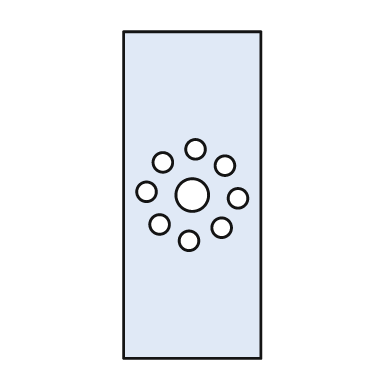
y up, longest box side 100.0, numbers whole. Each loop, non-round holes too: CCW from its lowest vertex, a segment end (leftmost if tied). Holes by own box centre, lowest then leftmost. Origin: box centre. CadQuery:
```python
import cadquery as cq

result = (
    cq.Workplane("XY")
    .moveTo(-21.0, -50.0)
    .lineTo(21.0, -50.0)
    .lineTo(21.0, 50.0)
    .lineTo(-21.0, 50.0)
    .close()
    .moveTo(-1.0, -14.0)
    .circle(3.0)
    .moveTo(9.0, -10.0)
    .circle(3.0)
    .moveTo(-10.0, -9.0)
    .circle(3.0)
    .moveTo(14.0, -1.0)
    .circle(3.0)
    .moveTo(0.0, 0.0)
    .circle(5.0)
    .moveTo(-14.0, 1.0)
    .circle(3.0)
    .moveTo(10.0, 9.0)
    .circle(3.0)
    .moveTo(-9.0, 10.0)
    .circle(3.0)
    .moveTo(1.0, 14.0)
    .circle(3.0)
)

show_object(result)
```